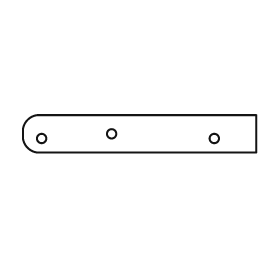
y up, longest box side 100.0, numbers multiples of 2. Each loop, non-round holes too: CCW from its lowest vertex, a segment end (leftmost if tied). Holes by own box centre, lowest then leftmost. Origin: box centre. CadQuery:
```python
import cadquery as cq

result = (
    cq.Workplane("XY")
    .moveTo(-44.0, -8.0)
    .lineTo(50.0, -8.0)
    .lineTo(50.0, 8.0)
    .lineTo(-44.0, 8.0)
    .threePointArc((-48.0, 6.0), (-50.0, 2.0))
    .lineTo(-50.0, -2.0)
    .threePointArc((-48.0, -6.0), (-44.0, -8.0))
    .close()
    .moveTo(-42.0, -2.0)
    .circle(2.0)
    .moveTo(32.0, -2.0)
    .circle(2.0)
    .moveTo(-12.0, 0.0)
    .circle(2.0)
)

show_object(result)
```